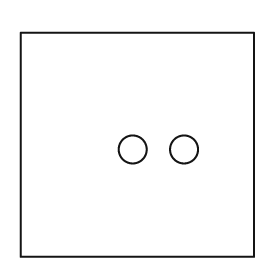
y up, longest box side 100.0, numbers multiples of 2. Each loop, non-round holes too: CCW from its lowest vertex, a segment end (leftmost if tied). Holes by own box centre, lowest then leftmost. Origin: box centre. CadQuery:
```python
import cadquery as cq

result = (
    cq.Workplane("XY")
    .moveTo(-50.0, -48.0)
    .lineTo(50.0, -48.0)
    .lineTo(50.0, 48.0)
    .lineTo(-50.0, 48.0)
    .close()
    .moveTo(-2.0, -2.0)
    .circle(6.0)
    .moveTo(20.0, -2.0)
    .circle(6.0)
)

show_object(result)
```